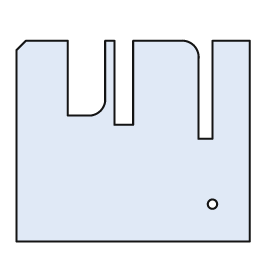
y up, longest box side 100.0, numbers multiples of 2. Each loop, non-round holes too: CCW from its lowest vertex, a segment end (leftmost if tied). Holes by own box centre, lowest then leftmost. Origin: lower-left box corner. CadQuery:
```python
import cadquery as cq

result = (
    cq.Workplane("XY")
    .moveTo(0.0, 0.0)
    .lineTo(100.0, 0.0)
    .lineTo(100.0, 86.0)
    .lineTo(84.0, 86.0)
    .lineTo(84.0, 44.0)
    .lineTo(78.0, 44.0)
    .lineTo(78.0, 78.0)
    .threePointArc((76.0, 84.0), (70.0, 86.0))
    .lineTo(50.0, 86.0)
    .lineTo(50.0, 50.0)
    .lineTo(42.0, 50.0)
    .lineTo(42.0, 86.0)
    .lineTo(38.0, 86.0)
    .lineTo(38.0, 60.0)
    .threePointArc((36.0, 56.0), (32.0, 54.0))
    .lineTo(22.0, 54.0)
    .lineTo(22.0, 86.0)
    .lineTo(4.0, 86.0)
    .lineTo(0.0, 82.0)
    .close()
    .moveTo(84.0, 16.0)
    .circle(2.0)
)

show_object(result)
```